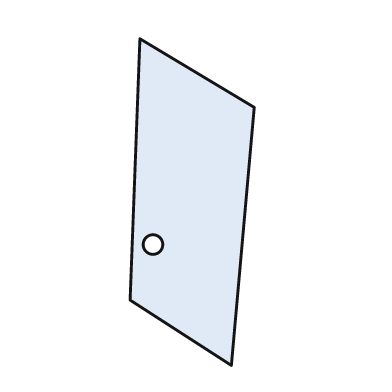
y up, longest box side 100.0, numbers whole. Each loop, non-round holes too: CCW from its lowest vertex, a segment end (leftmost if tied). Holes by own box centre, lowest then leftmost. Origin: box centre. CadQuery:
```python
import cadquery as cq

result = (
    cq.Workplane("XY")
    .moveTo(12.0, -50.0)
    .lineTo(19.0, 29.0)
    .lineTo(-16.0, 50.0)
    .lineTo(-19.0, -30.0)
    .close()
    .moveTo(-12.0, -13.0)
    .circle(3.0)
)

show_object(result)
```